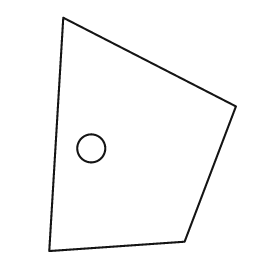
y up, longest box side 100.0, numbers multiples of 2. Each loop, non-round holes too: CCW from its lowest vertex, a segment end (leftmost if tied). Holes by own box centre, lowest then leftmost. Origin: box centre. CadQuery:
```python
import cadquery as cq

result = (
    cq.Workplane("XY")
    .moveTo(-40.0, -50.0)
    .lineTo(18.0, -46.0)
    .lineTo(40.0, 12.0)
    .lineTo(-34.0, 50.0)
    .close()
    .moveTo(-22.0, -6.0)
    .circle(6.0)
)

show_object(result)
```